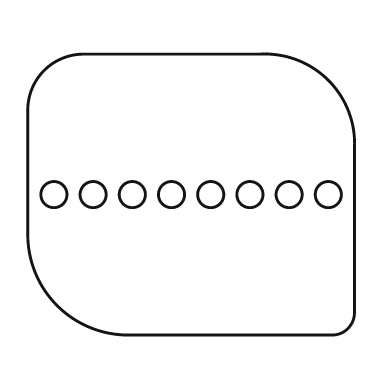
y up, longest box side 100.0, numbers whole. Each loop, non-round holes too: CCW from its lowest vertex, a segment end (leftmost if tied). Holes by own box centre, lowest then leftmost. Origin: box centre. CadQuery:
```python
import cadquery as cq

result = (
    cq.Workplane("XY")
    .moveTo(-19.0, -43.0)
    .lineTo(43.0, -43.0)
    .threePointArc((48.0, -41.0), (50.0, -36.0))
    .lineTo(50.0, 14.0)
    .threePointArc((42.0, 35.0), (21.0, 43.0))
    .lineTo(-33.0, 43.0)
    .threePointArc((-45.0, 38.0), (-50.0, 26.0))
    .lineTo(-50.0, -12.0)
    .threePointArc((-41.0, -34.0), (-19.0, -43.0))
    .close()
    .moveTo(-42.0, 0.0)
    .circle(4.0)
    .moveTo(-30.0, 0.0)
    .circle(4.0)
    .moveTo(-18.0, 0.0)
    .circle(4.0)
    .moveTo(-6.0, 0.0)
    .circle(4.0)
    .moveTo(6.0, 0.0)
    .circle(4.0)
    .moveTo(18.0, 0.0)
    .circle(4.0)
    .moveTo(30.0, 0.0)
    .circle(4.0)
    .moveTo(42.0, 0.0)
    .circle(4.0)
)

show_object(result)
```